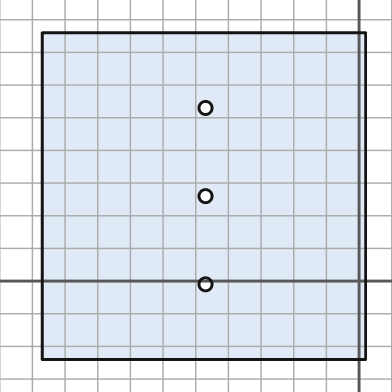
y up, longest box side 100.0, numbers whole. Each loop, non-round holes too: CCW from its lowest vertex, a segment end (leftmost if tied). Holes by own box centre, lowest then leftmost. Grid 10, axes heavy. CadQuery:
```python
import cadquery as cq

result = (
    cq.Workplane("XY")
    .moveTo(-97.0, -24.0)
    .lineTo(2.0, -24.0)
    .lineTo(2.0, 76.0)
    .lineTo(-97.0, 76.0)
    .close()
    .moveTo(-47.0, -1.0)
    .circle(2.0)
    .moveTo(-47.0, 26.0)
    .circle(2.0)
    .moveTo(-47.0, 53.0)
    .circle(2.0)
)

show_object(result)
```